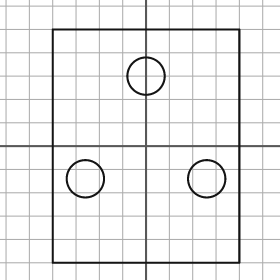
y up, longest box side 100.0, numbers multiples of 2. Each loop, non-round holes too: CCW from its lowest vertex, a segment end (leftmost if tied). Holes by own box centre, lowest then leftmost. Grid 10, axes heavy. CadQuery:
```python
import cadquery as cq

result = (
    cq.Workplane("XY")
    .moveTo(-40.0, -50.0)
    .lineTo(40.0, -50.0)
    .lineTo(40.0, 50.0)
    .lineTo(-40.0, 50.0)
    .close()
    .moveTo(-26.0, -14.0)
    .circle(8.0)
    .moveTo(26.0, -14.0)
    .circle(8.0)
    .moveTo(0.0, 30.0)
    .circle(8.0)
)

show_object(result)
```